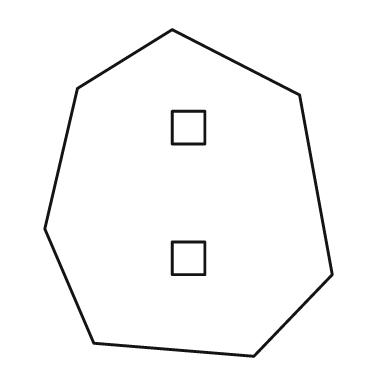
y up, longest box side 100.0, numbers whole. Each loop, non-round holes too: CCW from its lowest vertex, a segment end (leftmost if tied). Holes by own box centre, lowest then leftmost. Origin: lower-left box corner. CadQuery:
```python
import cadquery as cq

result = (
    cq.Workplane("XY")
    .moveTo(64.0, 0.0)
    .lineTo(88.0, 25.0)
    .lineTo(78.0, 80.0)
    .lineTo(39.0, 100.0)
    .lineTo(10.0, 82.0)
    .lineTo(0.0, 39.0)
    .lineTo(15.0, 4.0)
    .close()
    .moveTo(39.0, 25.0)
    .lineTo(49.0, 25.0)
    .lineTo(49.0, 35.0)
    .lineTo(39.0, 35.0)
    .close()
    .moveTo(39.0, 65.0)
    .lineTo(49.0, 65.0)
    .lineTo(49.0, 75.0)
    .lineTo(39.0, 75.0)
    .close()
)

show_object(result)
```